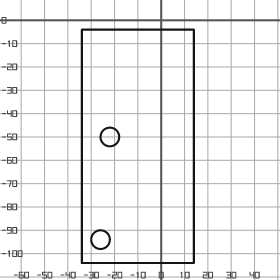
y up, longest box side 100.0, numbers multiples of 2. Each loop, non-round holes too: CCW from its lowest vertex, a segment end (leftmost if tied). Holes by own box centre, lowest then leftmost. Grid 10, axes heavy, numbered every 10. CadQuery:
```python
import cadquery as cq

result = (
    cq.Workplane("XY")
    .moveTo(-34.0, -104.0)
    .lineTo(14.0, -104.0)
    .lineTo(14.0, -4.0)
    .lineTo(-34.0, -4.0)
    .close()
    .moveTo(-26.0, -94.0)
    .circle(4.0)
    .moveTo(-22.0, -50.0)
    .circle(4.0)
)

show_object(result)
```